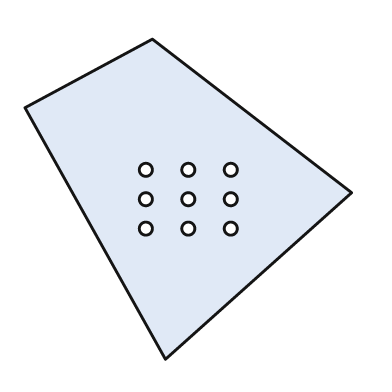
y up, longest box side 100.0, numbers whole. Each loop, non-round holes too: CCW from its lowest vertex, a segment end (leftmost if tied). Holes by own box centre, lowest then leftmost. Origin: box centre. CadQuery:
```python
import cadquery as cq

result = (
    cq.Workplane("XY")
    .moveTo(-7.0, -49.0)
    .lineTo(50.0, 2.0)
    .lineTo(-11.0, 49.0)
    .lineTo(-50.0, 28.0)
    .close()
    .moveTo(-13.0, -9.0)
    .circle(2.0)
    .moveTo(0.0, -9.0)
    .circle(2.0)
    .moveTo(13.0, -9.0)
    .circle(2.0)
    .moveTo(-13.0, 0.0)
    .circle(2.0)
    .moveTo(0.0, 0.0)
    .circle(2.0)
    .moveTo(13.0, 0.0)
    .circle(2.0)
    .moveTo(-13.0, 9.0)
    .circle(2.0)
    .moveTo(0.0, 9.0)
    .circle(2.0)
    .moveTo(13.0, 9.0)
    .circle(2.0)
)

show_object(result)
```